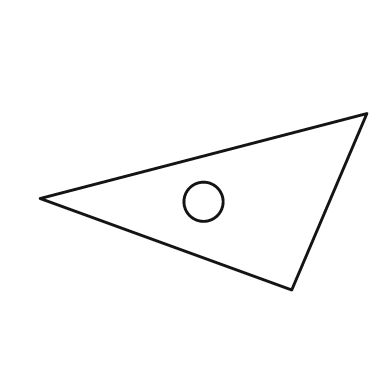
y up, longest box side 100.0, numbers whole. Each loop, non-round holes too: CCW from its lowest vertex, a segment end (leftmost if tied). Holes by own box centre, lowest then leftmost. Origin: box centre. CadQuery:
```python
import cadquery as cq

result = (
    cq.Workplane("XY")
    .moveTo(27.0, -27.0)
    .lineTo(50.0, 27.0)
    .lineTo(-50.0, 1.0)
    .close()
    .moveTo(0.0, 0.0)
    .circle(6.0)
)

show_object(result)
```